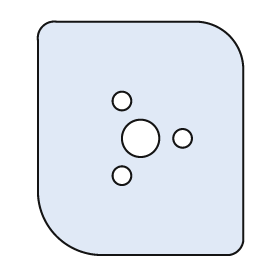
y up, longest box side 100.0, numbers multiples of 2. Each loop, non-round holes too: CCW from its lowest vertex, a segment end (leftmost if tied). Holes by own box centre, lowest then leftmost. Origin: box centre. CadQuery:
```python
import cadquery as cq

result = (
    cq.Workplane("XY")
    .moveTo(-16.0, -50.0)
    .lineTo(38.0, -50.0)
    .threePointArc((42.0, -48.0), (44.0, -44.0))
    .lineTo(44.0, 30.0)
    .threePointArc((38.0, 44.0), (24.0, 50.0))
    .lineTo(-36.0, 50.0)
    .threePointArc((-42.0, 48.0), (-44.0, 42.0))
    .lineTo(-44.0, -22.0)
    .threePointArc((-36.0, -42.0), (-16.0, -50.0))
    .close()
    .moveTo(-8.0, -16.0)
    .circle(4.0)
    .moveTo(0.0, 0.0)
    .circle(8.0)
    .moveTo(18.0, 0.0)
    .circle(4.0)
    .moveTo(-8.0, 16.0)
    .circle(4.0)
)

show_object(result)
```